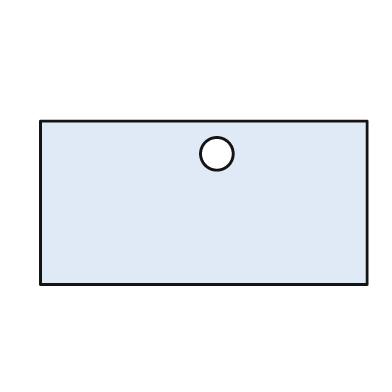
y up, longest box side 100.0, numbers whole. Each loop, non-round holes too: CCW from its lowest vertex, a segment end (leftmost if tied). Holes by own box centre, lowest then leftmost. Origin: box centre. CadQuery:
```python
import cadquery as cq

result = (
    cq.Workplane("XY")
    .moveTo(-50.0, -25.0)
    .lineTo(50.0, -25.0)
    .lineTo(50.0, 25.0)
    .lineTo(-50.0, 25.0)
    .close()
    .moveTo(4.0, 15.0)
    .circle(5.0)
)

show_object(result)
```